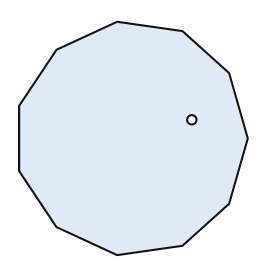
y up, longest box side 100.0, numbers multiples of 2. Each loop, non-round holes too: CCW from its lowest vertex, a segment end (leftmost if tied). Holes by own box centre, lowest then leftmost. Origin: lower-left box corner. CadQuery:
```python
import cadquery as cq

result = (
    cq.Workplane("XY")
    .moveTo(42.0, 0.0)
    .lineTo(70.0, 4.0)
    .lineTo(90.0, 22.0)
    .lineTo(98.0, 50.0)
    .lineTo(90.0, 78.0)
    .lineTo(70.0, 96.0)
    .lineTo(42.0, 100.0)
    .lineTo(16.0, 88.0)
    .lineTo(0.0, 64.0)
    .lineTo(0.0, 36.0)
    .lineTo(16.0, 12.0)
    .close()
    .moveTo(74.0, 58.0)
    .circle(2.0)
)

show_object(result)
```